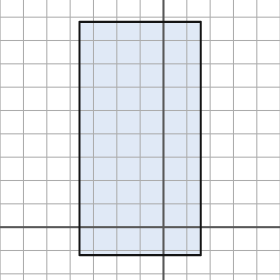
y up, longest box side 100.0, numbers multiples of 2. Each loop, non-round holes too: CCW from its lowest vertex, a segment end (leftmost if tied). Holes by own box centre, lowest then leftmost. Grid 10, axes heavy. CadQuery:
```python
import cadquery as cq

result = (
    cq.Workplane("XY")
    .moveTo(-36.0, -12.0)
    .lineTo(16.0, -12.0)
    .lineTo(16.0, 88.0)
    .lineTo(-36.0, 88.0)
    .close()
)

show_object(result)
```